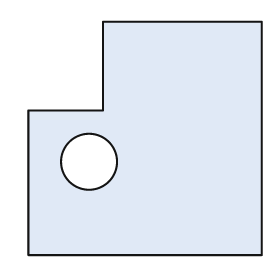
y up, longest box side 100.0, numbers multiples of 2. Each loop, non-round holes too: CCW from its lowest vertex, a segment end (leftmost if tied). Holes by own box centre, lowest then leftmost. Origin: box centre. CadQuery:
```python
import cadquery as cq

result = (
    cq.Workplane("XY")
    .moveTo(-50.0, -50.0)
    .lineTo(50.0, -50.0)
    .lineTo(50.0, 50.0)
    .lineTo(-18.0, 50.0)
    .lineTo(-18.0, 12.0)
    .lineTo(-50.0, 12.0)
    .close()
    .moveTo(-24.0, -10.0)
    .circle(12.0)
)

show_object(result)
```